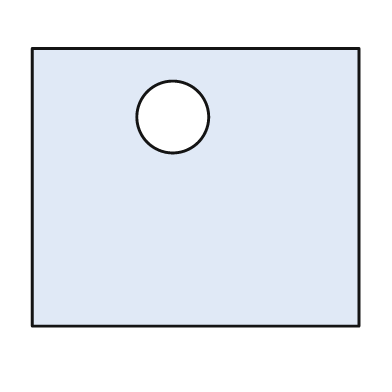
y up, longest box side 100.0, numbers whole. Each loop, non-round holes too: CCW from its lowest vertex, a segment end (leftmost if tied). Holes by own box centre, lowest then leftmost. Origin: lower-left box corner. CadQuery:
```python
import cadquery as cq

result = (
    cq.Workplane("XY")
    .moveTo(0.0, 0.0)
    .lineTo(100.0, 0.0)
    .lineTo(100.0, 85.0)
    .lineTo(0.0, 85.0)
    .close()
    .moveTo(43.0, 64.0)
    .circle(11.0)
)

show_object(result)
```